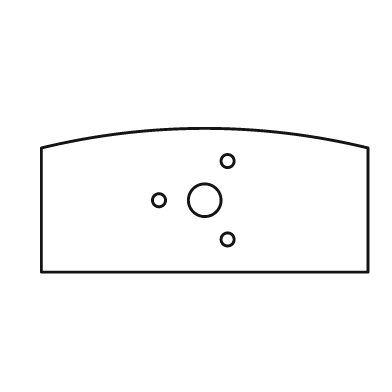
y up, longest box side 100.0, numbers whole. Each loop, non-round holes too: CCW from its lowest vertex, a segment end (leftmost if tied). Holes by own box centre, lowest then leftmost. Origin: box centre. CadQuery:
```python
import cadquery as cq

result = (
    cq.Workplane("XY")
    .moveTo(-50.0, -22.0)
    .lineTo(50.0, -22.0)
    .lineTo(50.0, 16.0)
    .threePointArc((0.0, 22.0), (-50.0, 16.0))
    .close()
    .moveTo(7.0, -12.0)
    .circle(2.0)
    .moveTo(-14.0, 0.0)
    .circle(2.0)
    .moveTo(0.0, 0.0)
    .circle(5.0)
    .moveTo(7.0, 12.0)
    .circle(2.0)
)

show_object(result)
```